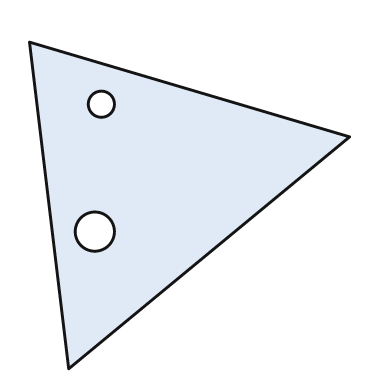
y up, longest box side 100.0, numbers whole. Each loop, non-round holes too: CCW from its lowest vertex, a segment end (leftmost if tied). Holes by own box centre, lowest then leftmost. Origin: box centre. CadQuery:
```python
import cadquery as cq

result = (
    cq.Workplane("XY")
    .moveTo(-37.0, -50.0)
    .lineTo(49.0, 21.0)
    .lineTo(-49.0, 50.0)
    .close()
    .moveTo(-29.0, -8.0)
    .circle(6.0)
    .moveTo(-27.0, 31.0)
    .circle(4.0)
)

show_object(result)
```